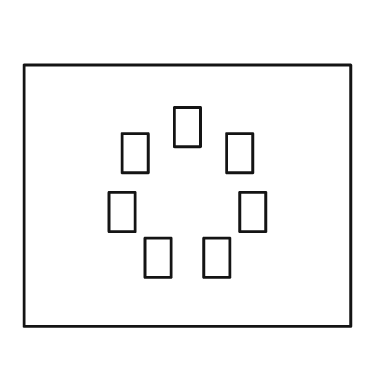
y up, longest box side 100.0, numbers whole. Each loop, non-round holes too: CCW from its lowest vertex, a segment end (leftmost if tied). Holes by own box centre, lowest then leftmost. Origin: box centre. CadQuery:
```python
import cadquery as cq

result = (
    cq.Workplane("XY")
    .moveTo(-50.0, -40.0)
    .lineTo(50.0, -40.0)
    .lineTo(50.0, 40.0)
    .lineTo(-50.0, 40.0)
    .close()
    .moveTo(-13.0, -25.0)
    .lineTo(-5.0, -25.0)
    .lineTo(-5.0, -13.0)
    .lineTo(-13.0, -13.0)
    .close()
    .moveTo(5.0, -25.0)
    .lineTo(13.0, -25.0)
    .lineTo(13.0, -13.0)
    .lineTo(5.0, -13.0)
    .close()
    .moveTo(-24.0, -11.0)
    .lineTo(-16.0, -11.0)
    .lineTo(-16.0, 1.0)
    .lineTo(-24.0, 1.0)
    .close()
    .moveTo(16.0, -11.0)
    .lineTo(24.0, -11.0)
    .lineTo(24.0, 1.0)
    .lineTo(16.0, 1.0)
    .close()
    .moveTo(-20.0, 7.0)
    .lineTo(-12.0, 7.0)
    .lineTo(-12.0, 19.0)
    .lineTo(-20.0, 19.0)
    .close()
    .moveTo(12.0, 7.0)
    .lineTo(20.0, 7.0)
    .lineTo(20.0, 19.0)
    .lineTo(12.0, 19.0)
    .close()
    .moveTo(-4.0, 15.0)
    .lineTo(4.0, 15.0)
    .lineTo(4.0, 27.0)
    .lineTo(-4.0, 27.0)
    .close()
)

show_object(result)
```